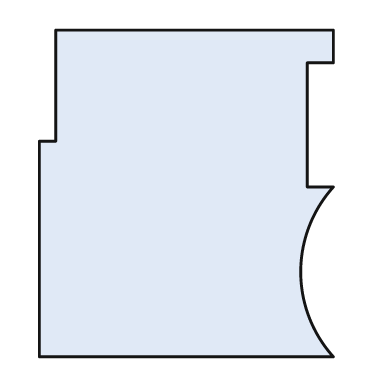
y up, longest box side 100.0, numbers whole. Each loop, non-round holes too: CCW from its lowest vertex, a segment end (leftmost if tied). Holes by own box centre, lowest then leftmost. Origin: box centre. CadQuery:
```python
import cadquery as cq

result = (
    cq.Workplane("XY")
    .moveTo(-45.0, -50.0)
    .lineTo(45.0, -50.0)
    .threePointArc((35.0, -24.0), (45.0, 2.0))
    .lineTo(37.0, 2.0)
    .lineTo(37.0, 40.0)
    .lineTo(45.0, 40.0)
    .lineTo(45.0, 50.0)
    .lineTo(-40.0, 50.0)
    .lineTo(-40.0, 16.0)
    .lineTo(-45.0, 16.0)
    .close()
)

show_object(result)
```